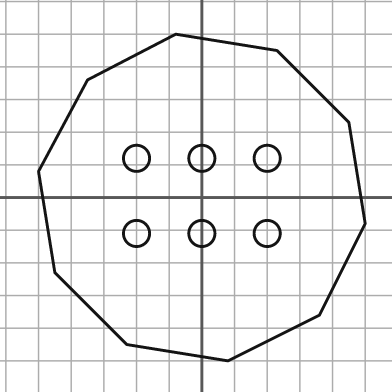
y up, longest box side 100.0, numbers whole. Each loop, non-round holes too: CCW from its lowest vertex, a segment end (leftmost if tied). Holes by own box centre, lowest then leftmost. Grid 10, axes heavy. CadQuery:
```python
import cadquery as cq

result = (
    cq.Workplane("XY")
    .moveTo(8.0, -50.0)
    .lineTo(36.0, -36.0)
    .lineTo(50.0, -8.0)
    .lineTo(45.0, 23.0)
    .lineTo(23.0, 45.0)
    .lineTo(-8.0, 50.0)
    .lineTo(-35.0, 36.0)
    .lineTo(-50.0, 8.0)
    .lineTo(-45.0, -23.0)
    .lineTo(-23.0, -45.0)
    .close()
    .moveTo(-20.0, -11.0)
    .circle(4.0)
    .moveTo(0.0, -11.0)
    .circle(4.0)
    .moveTo(20.0, -11.0)
    .circle(4.0)
    .moveTo(-20.0, 12.0)
    .circle(4.0)
    .moveTo(0.0, 12.0)
    .circle(4.0)
    .moveTo(20.0, 12.0)
    .circle(4.0)
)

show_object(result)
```